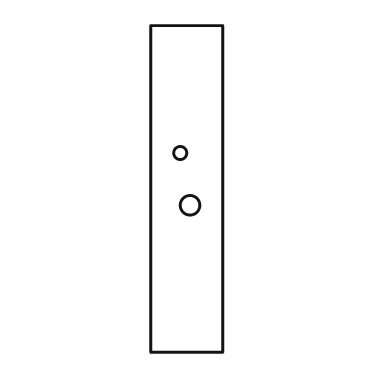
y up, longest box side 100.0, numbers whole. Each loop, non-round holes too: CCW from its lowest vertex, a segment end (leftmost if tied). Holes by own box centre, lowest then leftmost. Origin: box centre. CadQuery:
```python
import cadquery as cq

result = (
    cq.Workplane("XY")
    .moveTo(-11.0, -50.0)
    .lineTo(11.0, -50.0)
    .lineTo(11.0, 50.0)
    .lineTo(-11.0, 50.0)
    .close()
    .moveTo(1.0, -5.0)
    .circle(3.0)
    .moveTo(-2.0, 11.0)
    .circle(2.0)
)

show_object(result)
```